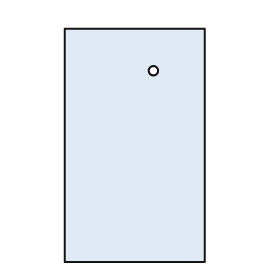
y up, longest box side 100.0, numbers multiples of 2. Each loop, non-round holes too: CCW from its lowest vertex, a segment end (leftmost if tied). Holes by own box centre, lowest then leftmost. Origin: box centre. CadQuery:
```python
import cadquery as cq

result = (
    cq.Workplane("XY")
    .moveTo(-30.0, -50.0)
    .lineTo(30.0, -50.0)
    .lineTo(30.0, 50.0)
    .lineTo(-30.0, 50.0)
    .close()
    .moveTo(8.0, 32.0)
    .circle(2.0)
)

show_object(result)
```